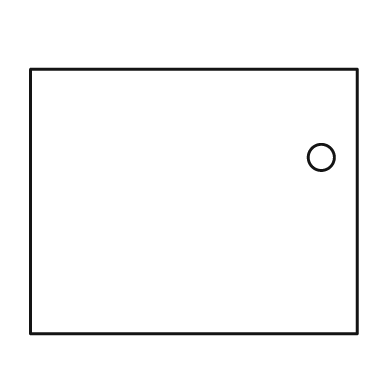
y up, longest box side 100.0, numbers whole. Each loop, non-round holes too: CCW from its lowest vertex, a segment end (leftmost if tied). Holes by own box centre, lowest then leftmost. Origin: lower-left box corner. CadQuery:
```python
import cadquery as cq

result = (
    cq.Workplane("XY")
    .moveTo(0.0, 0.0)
    .lineTo(100.0, 0.0)
    .lineTo(100.0, 81.0)
    .lineTo(0.0, 81.0)
    .close()
    .moveTo(89.0, 54.0)
    .circle(4.0)
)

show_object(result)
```